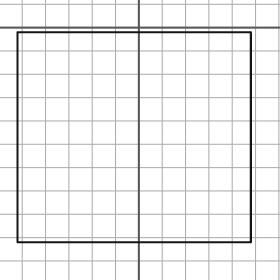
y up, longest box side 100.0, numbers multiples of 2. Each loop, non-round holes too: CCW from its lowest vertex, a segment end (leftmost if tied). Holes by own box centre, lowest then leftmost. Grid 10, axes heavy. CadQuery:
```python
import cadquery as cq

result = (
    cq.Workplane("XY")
    .moveTo(-52.0, -92.0)
    .lineTo(48.0, -92.0)
    .lineTo(48.0, -2.0)
    .lineTo(-52.0, -2.0)
    .close()
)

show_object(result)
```